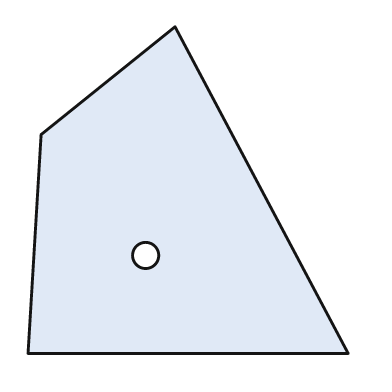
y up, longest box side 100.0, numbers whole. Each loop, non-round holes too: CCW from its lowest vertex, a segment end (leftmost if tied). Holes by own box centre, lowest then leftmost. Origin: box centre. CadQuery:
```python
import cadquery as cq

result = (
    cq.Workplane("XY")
    .moveTo(-49.0, -50.0)
    .lineTo(49.0, -50.0)
    .lineTo(-4.0, 50.0)
    .lineTo(-45.0, 17.0)
    .close()
    .moveTo(-13.0, -20.0)
    .circle(4.0)
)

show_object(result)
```